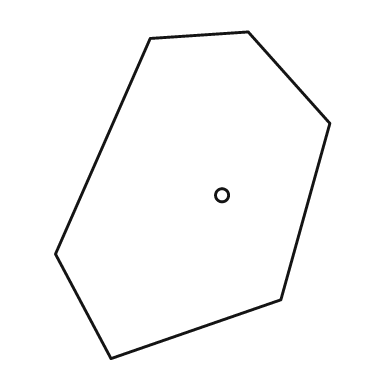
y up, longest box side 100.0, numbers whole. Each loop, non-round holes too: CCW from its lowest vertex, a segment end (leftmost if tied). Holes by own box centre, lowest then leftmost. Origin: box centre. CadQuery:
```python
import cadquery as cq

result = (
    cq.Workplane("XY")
    .moveTo(-25.0, -50.0)
    .lineTo(27.0, -32.0)
    .lineTo(42.0, 22.0)
    .lineTo(17.0, 50.0)
    .lineTo(-13.0, 48.0)
    .lineTo(-42.0, -18.0)
    .close()
    .moveTo(9.0, 0.0)
    .circle(2.0)
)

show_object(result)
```